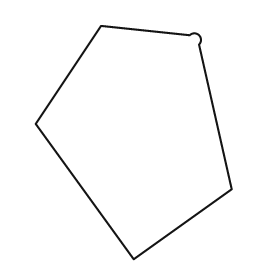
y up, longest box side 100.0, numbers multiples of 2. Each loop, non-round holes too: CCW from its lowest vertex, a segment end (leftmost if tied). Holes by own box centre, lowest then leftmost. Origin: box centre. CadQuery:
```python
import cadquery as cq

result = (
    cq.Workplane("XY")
    .moveTo(0.0, -50.0)
    .lineTo(42.0, -20.0)
    .lineTo(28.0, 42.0)
    .threePointArc((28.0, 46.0), (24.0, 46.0))
    .lineTo(-14.0, 50.0)
    .lineTo(-42.0, 8.0)
    .close()
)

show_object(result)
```